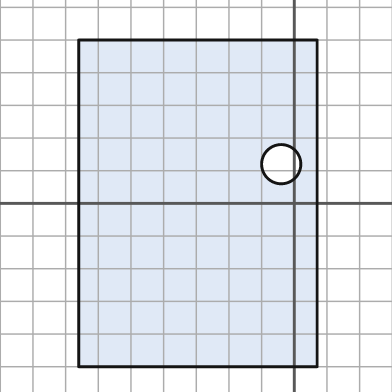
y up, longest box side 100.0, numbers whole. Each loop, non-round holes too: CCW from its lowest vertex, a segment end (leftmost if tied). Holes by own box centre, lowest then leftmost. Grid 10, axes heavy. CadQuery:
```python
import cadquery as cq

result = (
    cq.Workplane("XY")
    .moveTo(-66.0, -50.0)
    .lineTo(7.0, -50.0)
    .lineTo(7.0, 50.0)
    .lineTo(-66.0, 50.0)
    .close()
    .moveTo(-4.0, 12.0)
    .circle(6.0)
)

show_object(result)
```